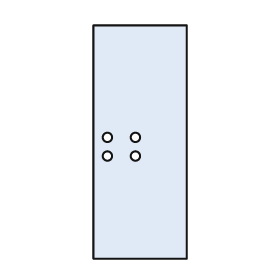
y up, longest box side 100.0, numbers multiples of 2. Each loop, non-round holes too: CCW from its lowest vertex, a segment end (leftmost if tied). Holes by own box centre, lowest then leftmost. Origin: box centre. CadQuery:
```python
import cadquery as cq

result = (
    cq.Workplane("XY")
    .moveTo(-20.0, -50.0)
    .lineTo(20.0, -50.0)
    .lineTo(20.0, 50.0)
    .lineTo(-20.0, 50.0)
    .close()
    .moveTo(-14.0, -6.0)
    .circle(2.0)
    .moveTo(-2.0, -6.0)
    .circle(2.0)
    .moveTo(-14.0, 2.0)
    .circle(2.0)
    .moveTo(-2.0, 2.0)
    .circle(2.0)
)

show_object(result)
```